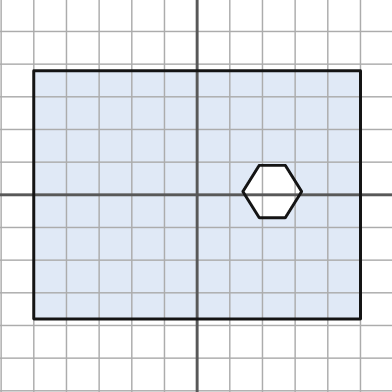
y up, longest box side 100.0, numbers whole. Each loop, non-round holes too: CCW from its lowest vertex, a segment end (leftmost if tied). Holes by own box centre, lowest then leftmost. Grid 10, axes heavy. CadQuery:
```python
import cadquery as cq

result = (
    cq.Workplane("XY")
    .moveTo(-50.0, -38.0)
    .lineTo(50.0, -38.0)
    .lineTo(50.0, 38.0)
    .lineTo(-50.0, 38.0)
    .close()
    .moveTo(19.0, -7.0)
    .lineTo(27.0, -7.0)
    .lineTo(32.0, 1.0)
    .lineTo(27.0, 9.0)
    .lineTo(19.0, 9.0)
    .lineTo(14.0, 1.0)
    .close()
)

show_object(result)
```